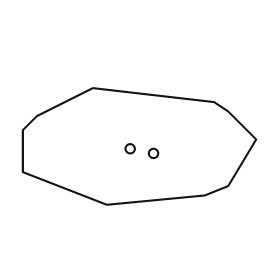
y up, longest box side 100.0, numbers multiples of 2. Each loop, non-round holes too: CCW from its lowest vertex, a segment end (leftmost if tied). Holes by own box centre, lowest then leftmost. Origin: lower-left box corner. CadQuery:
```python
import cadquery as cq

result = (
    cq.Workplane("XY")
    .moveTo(36.0, 0.0)
    .lineTo(78.0, 4.0)
    .lineTo(88.0, 8.0)
    .lineTo(100.0, 28.0)
    .lineTo(88.0, 40.0)
    .lineTo(82.0, 44.0)
    .lineTo(30.0, 50.0)
    .lineTo(6.0, 38.0)
    .lineTo(0.0, 32.0)
    .lineTo(0.0, 14.0)
    .close()
    .moveTo(56.0, 22.0)
    .circle(2.0)
    .moveTo(46.0, 24.0)
    .circle(2.0)
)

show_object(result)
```